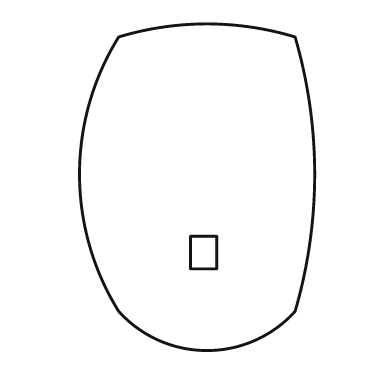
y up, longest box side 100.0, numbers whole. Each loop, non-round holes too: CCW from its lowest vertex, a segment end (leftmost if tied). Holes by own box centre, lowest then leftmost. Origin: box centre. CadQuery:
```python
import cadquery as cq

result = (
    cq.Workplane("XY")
    .moveTo(-24.0, -38.0)
    .threePointArc((3.0, -50.0), (30.0, -38.0))
    .threePointArc((36.0, 4.0), (30.0, 46.0))
    .threePointArc((3.0, 50.0), (-24.0, 46.0))
    .threePointArc((-36.0, 4.0), (-24.0, -38.0))
    .close()
    .moveTo(-2.0, -25.0)
    .lineTo(6.0, -25.0)
    .lineTo(6.0, -15.0)
    .lineTo(-2.0, -15.0)
    .close()
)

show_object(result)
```